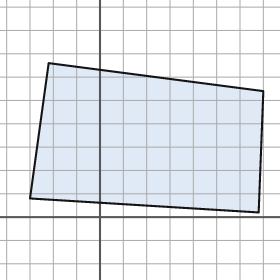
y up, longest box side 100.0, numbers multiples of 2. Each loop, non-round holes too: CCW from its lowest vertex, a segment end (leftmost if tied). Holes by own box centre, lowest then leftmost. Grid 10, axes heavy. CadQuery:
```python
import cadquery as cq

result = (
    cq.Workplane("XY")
    .moveTo(68.0, 2.0)
    .lineTo(70.0, 54.0)
    .lineTo(-22.0, 66.0)
    .lineTo(-30.0, 8.0)
    .close()
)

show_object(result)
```